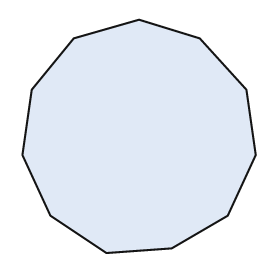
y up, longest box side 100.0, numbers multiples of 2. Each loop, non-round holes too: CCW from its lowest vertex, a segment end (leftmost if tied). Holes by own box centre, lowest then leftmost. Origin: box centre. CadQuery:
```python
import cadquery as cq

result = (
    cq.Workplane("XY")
    .moveTo(-14.0, -50.0)
    .lineTo(14.0, -48.0)
    .lineTo(38.0, -34.0)
    .lineTo(50.0, -8.0)
    .lineTo(46.0, 20.0)
    .lineTo(26.0, 42.0)
    .lineTo(0.0, 50.0)
    .lineTo(-28.0, 42.0)
    .lineTo(-46.0, 20.0)
    .lineTo(-50.0, -8.0)
    .lineTo(-38.0, -34.0)
    .close()
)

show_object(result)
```